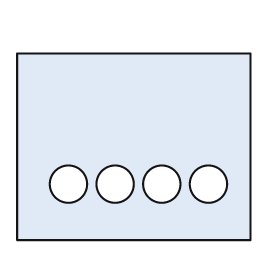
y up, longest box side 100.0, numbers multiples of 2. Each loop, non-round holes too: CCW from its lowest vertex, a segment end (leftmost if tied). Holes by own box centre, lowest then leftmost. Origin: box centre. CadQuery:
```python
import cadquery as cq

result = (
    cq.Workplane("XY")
    .moveTo(-50.0, -40.0)
    .lineTo(50.0, -40.0)
    .lineTo(50.0, 40.0)
    .lineTo(-50.0, 40.0)
    .close()
    .moveTo(-28.0, -16.0)
    .circle(8.0)
    .moveTo(-8.0, -16.0)
    .circle(8.0)
    .moveTo(12.0, -16.0)
    .circle(8.0)
    .moveTo(32.0, -16.0)
    .circle(8.0)
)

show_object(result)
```